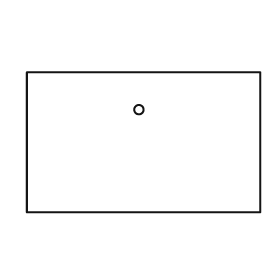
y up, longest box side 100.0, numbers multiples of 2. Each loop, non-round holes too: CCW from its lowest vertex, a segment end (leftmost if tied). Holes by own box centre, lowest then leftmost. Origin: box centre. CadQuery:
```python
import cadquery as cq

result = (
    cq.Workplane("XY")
    .moveTo(-50.0, -30.0)
    .lineTo(50.0, -30.0)
    .lineTo(50.0, 30.0)
    .lineTo(-50.0, 30.0)
    .close()
    .moveTo(-2.0, 14.0)
    .circle(2.0)
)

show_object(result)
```